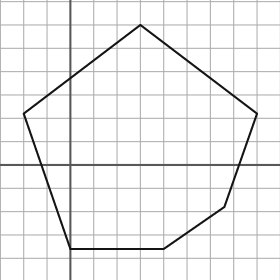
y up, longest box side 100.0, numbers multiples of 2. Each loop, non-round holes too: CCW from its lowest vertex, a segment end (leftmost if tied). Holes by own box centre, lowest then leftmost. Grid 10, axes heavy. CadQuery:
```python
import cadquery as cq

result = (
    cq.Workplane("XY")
    .moveTo(0.0, -36.0)
    .lineTo(40.0, -36.0)
    .lineTo(66.0, -18.0)
    .lineTo(80.0, 22.0)
    .lineTo(30.0, 60.0)
    .lineTo(-20.0, 22.0)
    .close()
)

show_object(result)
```